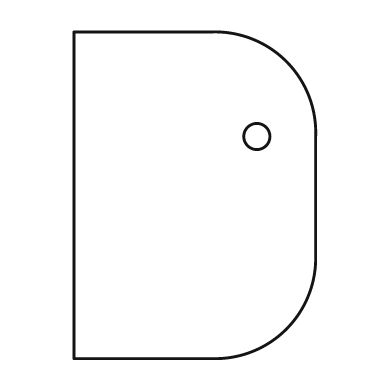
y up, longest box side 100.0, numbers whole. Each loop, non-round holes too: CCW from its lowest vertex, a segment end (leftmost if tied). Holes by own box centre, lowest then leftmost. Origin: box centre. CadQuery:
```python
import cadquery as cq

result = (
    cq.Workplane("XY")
    .moveTo(-37.0, -50.0)
    .lineTo(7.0, -50.0)
    .threePointArc((28.0, -41.0), (37.0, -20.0))
    .lineTo(37.0, 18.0)
    .threePointArc((28.0, 41.0), (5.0, 50.0))
    .lineTo(-37.0, 50.0)
    .close()
    .moveTo(19.0, 18.0)
    .circle(4.0)
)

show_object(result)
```